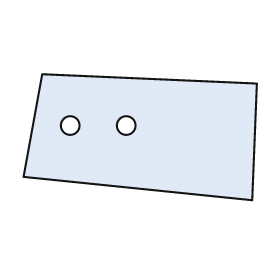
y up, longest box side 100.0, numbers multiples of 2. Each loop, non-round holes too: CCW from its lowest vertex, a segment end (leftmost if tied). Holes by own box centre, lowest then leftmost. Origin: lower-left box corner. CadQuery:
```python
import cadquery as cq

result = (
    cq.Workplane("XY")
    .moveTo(98.0, 0.0)
    .lineTo(100.0, 50.0)
    .lineTo(8.0, 54.0)
    .lineTo(0.0, 10.0)
    .close()
    .moveTo(20.0, 32.0)
    .circle(4.0)
    .moveTo(44.0, 32.0)
    .circle(4.0)
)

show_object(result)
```